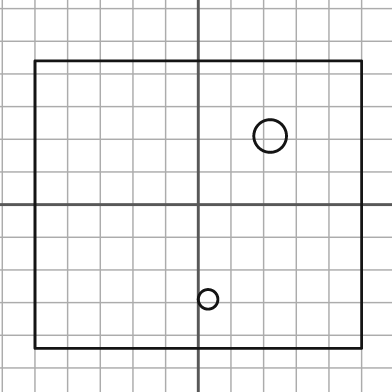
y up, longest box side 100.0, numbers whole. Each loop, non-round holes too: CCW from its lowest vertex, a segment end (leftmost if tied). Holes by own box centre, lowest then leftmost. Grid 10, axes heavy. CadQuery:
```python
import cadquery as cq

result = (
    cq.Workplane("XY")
    .moveTo(-50.0, -44.0)
    .lineTo(50.0, -44.0)
    .lineTo(50.0, 44.0)
    .lineTo(-50.0, 44.0)
    .close()
    .moveTo(3.0, -29.0)
    .circle(3.0)
    .moveTo(22.0, 21.0)
    .circle(5.0)
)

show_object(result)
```